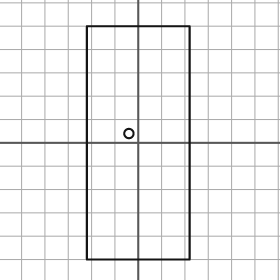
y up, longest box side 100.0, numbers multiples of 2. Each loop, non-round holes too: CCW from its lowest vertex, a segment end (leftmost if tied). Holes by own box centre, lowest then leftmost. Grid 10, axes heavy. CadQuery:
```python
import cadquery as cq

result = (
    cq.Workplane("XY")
    .moveTo(-22.0, -50.0)
    .lineTo(22.0, -50.0)
    .lineTo(22.0, 50.0)
    .lineTo(-22.0, 50.0)
    .close()
    .moveTo(-4.0, 4.0)
    .circle(2.0)
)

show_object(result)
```